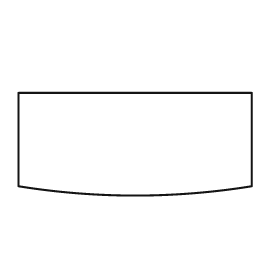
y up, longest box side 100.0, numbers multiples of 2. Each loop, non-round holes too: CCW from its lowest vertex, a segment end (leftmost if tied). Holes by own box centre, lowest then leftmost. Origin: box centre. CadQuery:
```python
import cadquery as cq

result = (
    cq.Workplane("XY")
    .moveTo(-50.0, -18.0)
    .threePointArc((0.0, -22.0), (50.0, -18.0))
    .lineTo(50.0, 22.0)
    .lineTo(-50.0, 22.0)
    .close()
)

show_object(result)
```